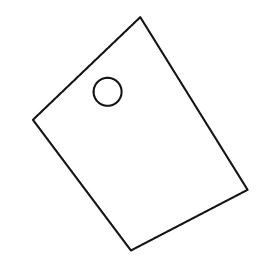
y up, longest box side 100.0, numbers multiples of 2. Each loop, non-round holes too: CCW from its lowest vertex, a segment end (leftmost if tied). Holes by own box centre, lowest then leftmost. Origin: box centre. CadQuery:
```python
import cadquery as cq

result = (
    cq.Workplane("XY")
    .moveTo(-4.0, -50.0)
    .lineTo(46.0, -24.0)
    .lineTo(0.0, 50.0)
    .lineTo(-46.0, 6.0)
    .close()
    .moveTo(-14.0, 18.0)
    .circle(6.0)
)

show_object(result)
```